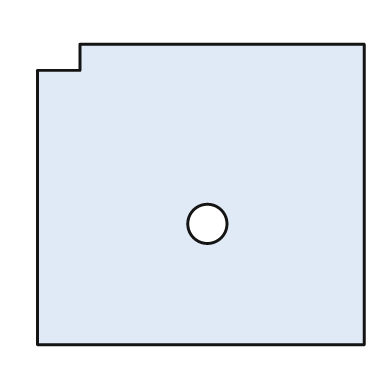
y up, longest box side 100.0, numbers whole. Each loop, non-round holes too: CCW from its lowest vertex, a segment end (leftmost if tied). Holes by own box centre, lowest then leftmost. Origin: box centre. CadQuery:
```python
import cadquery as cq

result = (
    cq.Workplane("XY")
    .moveTo(-50.0, -46.0)
    .lineTo(50.0, -46.0)
    .lineTo(50.0, 46.0)
    .lineTo(-37.0, 46.0)
    .lineTo(-37.0, 38.0)
    .lineTo(-50.0, 38.0)
    .close()
    .moveTo(2.0, -9.0)
    .circle(6.0)
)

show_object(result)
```